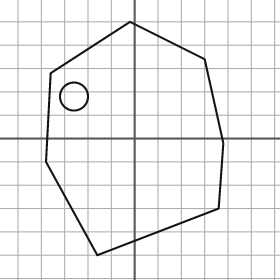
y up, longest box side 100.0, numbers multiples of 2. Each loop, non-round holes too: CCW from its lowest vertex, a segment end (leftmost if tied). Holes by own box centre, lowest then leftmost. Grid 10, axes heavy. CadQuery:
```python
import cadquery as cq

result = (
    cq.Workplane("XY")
    .moveTo(-16.0, -50.0)
    .lineTo(36.0, -30.0)
    .lineTo(38.0, -2.0)
    .lineTo(30.0, 34.0)
    .lineTo(-2.0, 50.0)
    .lineTo(-36.0, 28.0)
    .lineTo(-38.0, -10.0)
    .close()
    .moveTo(-26.0, 18.0)
    .circle(6.0)
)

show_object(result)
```